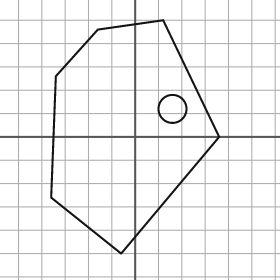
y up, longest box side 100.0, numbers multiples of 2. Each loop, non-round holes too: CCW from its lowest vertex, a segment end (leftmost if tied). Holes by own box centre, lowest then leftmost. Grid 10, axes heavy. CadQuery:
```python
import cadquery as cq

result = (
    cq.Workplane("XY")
    .moveTo(-6.0, -50.0)
    .lineTo(36.0, 0.0)
    .lineTo(12.0, 50.0)
    .lineTo(-16.0, 46.0)
    .lineTo(-34.0, 26.0)
    .lineTo(-36.0, -26.0)
    .close()
    .moveTo(16.0, 12.0)
    .circle(6.0)
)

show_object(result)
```